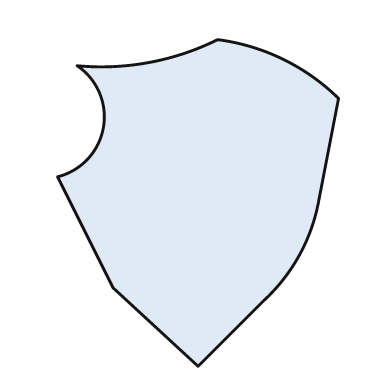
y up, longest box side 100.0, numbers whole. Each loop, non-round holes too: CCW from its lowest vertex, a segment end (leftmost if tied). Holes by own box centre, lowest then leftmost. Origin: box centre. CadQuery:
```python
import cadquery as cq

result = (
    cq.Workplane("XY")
    .moveTo(0.0, -50.0)
    .lineTo(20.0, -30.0)
    .threePointArc((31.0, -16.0), (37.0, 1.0))
    .lineTo(43.0, 32.0)
    .threePointArc((26.0, 44.0), (6.0, 50.0))
    .threePointArc((-15.0, 43.0), (-37.0, 42.0))
    .threePointArc((-29.0, 23.0), (-43.0, 8.0))
    .lineTo(-26.0, -26.0)
    .close()
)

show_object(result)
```